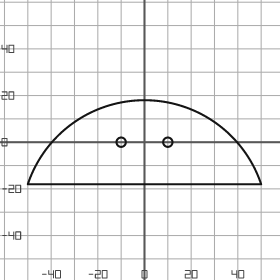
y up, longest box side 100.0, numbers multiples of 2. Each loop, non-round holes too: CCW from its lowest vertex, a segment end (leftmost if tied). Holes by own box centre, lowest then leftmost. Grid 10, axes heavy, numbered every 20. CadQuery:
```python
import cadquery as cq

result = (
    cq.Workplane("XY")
    .moveTo(-50.0, -18.0)
    .lineTo(50.0, -18.0)
    .threePointArc((0.0, 18.0), (-50.0, -18.0))
    .close()
    .moveTo(-10.0, 0.0)
    .circle(2.0)
    .moveTo(10.0, 0.0)
    .circle(2.0)
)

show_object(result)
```